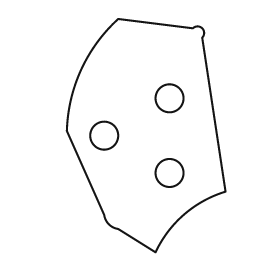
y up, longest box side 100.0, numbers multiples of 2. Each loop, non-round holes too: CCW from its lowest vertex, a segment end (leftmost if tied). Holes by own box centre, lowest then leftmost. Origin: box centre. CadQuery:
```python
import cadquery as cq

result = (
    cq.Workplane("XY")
    .moveTo(4.0, -50.0)
    .threePointArc((16.0, -34.0), (34.0, -24.0))
    .lineTo(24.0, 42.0)
    .threePointArc((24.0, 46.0), (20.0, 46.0))
    .lineTo(-12.0, 50.0)
    .threePointArc((-28.0, 28.0), (-34.0, 2.0))
    .lineTo(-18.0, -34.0)
    .threePointArc((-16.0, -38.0), (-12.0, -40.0))
    .close()
    .moveTo(10.0, -16.0)
    .circle(6.0)
    .moveTo(-18.0, 0.0)
    .circle(6.0)
    .moveTo(10.0, 16.0)
    .circle(6.0)
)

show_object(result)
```